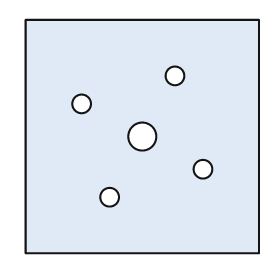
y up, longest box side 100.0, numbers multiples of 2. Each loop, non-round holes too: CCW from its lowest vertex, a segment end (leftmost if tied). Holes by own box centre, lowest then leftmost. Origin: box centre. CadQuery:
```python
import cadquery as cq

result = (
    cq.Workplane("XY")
    .moveTo(-50.0, -50.0)
    .lineTo(50.0, -50.0)
    .lineTo(50.0, 50.0)
    .lineTo(-50.0, 50.0)
    .close()
    .moveTo(-14.0, -26.0)
    .circle(4.0)
    .moveTo(26.0, -14.0)
    .circle(4.0)
    .moveTo(0.0, 0.0)
    .circle(6.0)
    .moveTo(-26.0, 14.0)
    .circle(4.0)
    .moveTo(14.0, 26.0)
    .circle(4.0)
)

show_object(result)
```